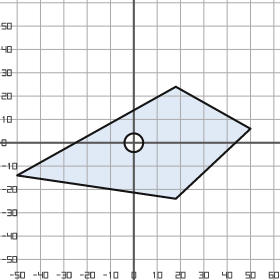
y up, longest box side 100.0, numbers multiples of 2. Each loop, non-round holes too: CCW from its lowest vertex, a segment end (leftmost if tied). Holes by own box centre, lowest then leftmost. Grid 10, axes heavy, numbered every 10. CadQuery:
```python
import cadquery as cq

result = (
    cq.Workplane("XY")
    .moveTo(18.0, -24.0)
    .lineTo(50.0, 6.0)
    .lineTo(18.0, 24.0)
    .lineTo(-50.0, -14.0)
    .close()
    .moveTo(0.0, 0.0)
    .circle(4.0)
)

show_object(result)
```